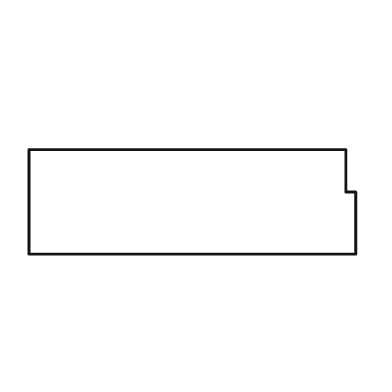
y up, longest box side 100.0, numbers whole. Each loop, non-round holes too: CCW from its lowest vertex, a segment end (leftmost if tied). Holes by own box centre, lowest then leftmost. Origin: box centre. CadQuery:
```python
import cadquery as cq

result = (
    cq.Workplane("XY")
    .moveTo(-50.0, -16.0)
    .lineTo(50.0, -16.0)
    .lineTo(50.0, 3.0)
    .lineTo(47.0, 3.0)
    .lineTo(47.0, 16.0)
    .lineTo(-50.0, 16.0)
    .close()
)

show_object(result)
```